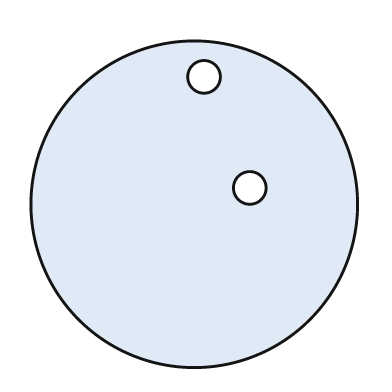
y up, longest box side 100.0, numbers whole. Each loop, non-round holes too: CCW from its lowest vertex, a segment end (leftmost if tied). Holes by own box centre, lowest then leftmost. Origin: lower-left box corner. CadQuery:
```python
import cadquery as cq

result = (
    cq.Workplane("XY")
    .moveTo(50.0, 50.0)
    .circle(50.0)
    .moveTo(67.0, 55.0)
    .circle(5.0)
    .moveTo(53.0, 89.0)
    .circle(5.0)
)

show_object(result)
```